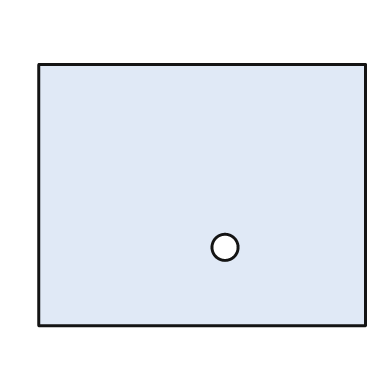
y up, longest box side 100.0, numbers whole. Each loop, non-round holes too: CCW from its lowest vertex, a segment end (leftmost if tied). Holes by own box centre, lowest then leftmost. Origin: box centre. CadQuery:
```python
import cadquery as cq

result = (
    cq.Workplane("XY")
    .moveTo(-50.0, -40.0)
    .lineTo(50.0, -40.0)
    .lineTo(50.0, 40.0)
    .lineTo(-50.0, 40.0)
    .close()
    .moveTo(7.0, -16.0)
    .circle(4.0)
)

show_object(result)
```